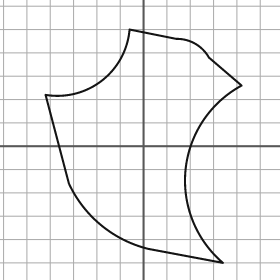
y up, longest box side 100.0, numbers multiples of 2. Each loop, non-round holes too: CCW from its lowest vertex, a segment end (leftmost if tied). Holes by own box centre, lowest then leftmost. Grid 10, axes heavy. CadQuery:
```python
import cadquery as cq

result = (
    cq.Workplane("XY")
    .moveTo(34.0, -50.0)
    .threePointArc((18.0, -10.0), (42.0, 26.0))
    .lineTo(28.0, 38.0)
    .threePointArc((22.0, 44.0), (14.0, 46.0))
    .lineTo(-6.0, 50.0)
    .threePointArc((-18.0, 28.0), (-42.0, 22.0))
    .lineTo(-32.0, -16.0)
    .threePointArc((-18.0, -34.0), (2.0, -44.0))
    .close()
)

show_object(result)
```